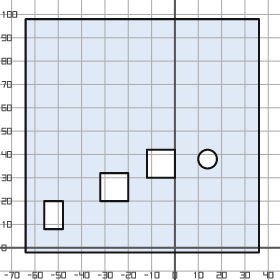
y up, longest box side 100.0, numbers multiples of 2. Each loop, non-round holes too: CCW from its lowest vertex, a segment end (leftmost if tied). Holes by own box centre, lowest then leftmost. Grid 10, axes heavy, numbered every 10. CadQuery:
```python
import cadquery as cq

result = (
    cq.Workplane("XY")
    .moveTo(-64.0, -2.0)
    .lineTo(36.0, -2.0)
    .lineTo(36.0, 98.0)
    .lineTo(-64.0, 98.0)
    .close()
    .moveTo(-56.0, 8.0)
    .lineTo(-48.0, 8.0)
    .lineTo(-48.0, 20.0)
    .lineTo(-56.0, 20.0)
    .close()
    .moveTo(-32.0, 20.0)
    .lineTo(-20.0, 20.0)
    .lineTo(-20.0, 32.0)
    .lineTo(-32.0, 32.0)
    .close()
    .moveTo(-12.0, 30.0)
    .lineTo(0.0, 30.0)
    .lineTo(0.0, 42.0)
    .lineTo(-12.0, 42.0)
    .close()
    .moveTo(14.0, 38.0)
    .circle(4.0)
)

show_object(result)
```